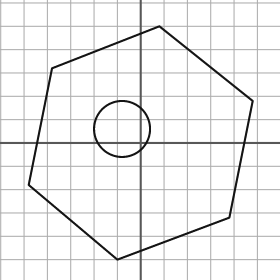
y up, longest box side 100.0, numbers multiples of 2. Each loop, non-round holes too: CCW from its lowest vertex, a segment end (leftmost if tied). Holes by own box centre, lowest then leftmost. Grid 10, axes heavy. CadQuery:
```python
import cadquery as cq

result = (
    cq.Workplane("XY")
    .moveTo(-10.0, -50.0)
    .lineTo(38.0, -32.0)
    .lineTo(48.0, 18.0)
    .lineTo(8.0, 50.0)
    .lineTo(-38.0, 32.0)
    .lineTo(-48.0, -18.0)
    .close()
    .moveTo(-8.0, 6.0)
    .circle(12.0)
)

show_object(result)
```